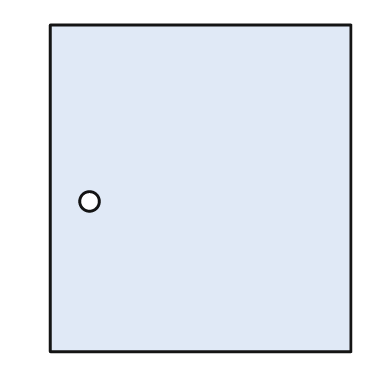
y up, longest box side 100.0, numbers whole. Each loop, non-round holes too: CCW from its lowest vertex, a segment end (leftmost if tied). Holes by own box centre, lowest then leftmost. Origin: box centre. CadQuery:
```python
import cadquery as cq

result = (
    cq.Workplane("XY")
    .moveTo(-46.0, -50.0)
    .lineTo(46.0, -50.0)
    .lineTo(46.0, 50.0)
    .lineTo(-46.0, 50.0)
    .close()
    .moveTo(-34.0, -4.0)
    .circle(3.0)
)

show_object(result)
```